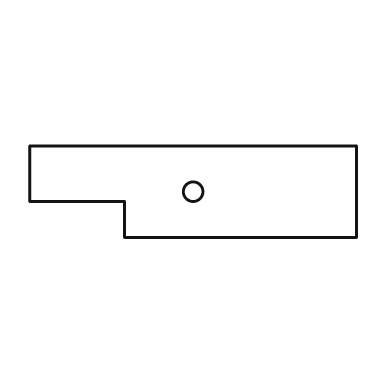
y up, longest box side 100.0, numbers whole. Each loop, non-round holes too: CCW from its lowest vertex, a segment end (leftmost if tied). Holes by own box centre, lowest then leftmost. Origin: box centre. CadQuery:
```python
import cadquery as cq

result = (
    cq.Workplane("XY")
    .moveTo(-21.0, -14.0)
    .lineTo(50.0, -14.0)
    .lineTo(50.0, 14.0)
    .lineTo(-50.0, 14.0)
    .lineTo(-50.0, -3.0)
    .lineTo(-21.0, -3.0)
    .close()
    .moveTo(0.0, 0.0)
    .circle(3.0)
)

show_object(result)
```